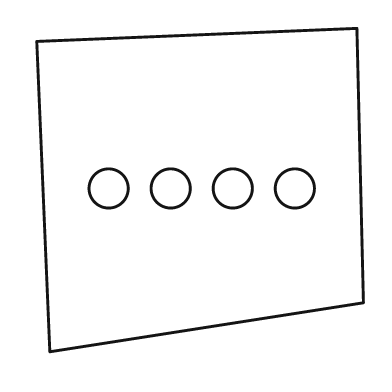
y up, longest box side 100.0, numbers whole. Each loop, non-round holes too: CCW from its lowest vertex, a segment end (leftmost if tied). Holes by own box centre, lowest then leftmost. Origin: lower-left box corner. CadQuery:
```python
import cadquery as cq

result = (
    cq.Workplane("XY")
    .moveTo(4.0, 0.0)
    .lineTo(100.0, 15.0)
    .lineTo(98.0, 99.0)
    .lineTo(0.0, 95.0)
    .close()
    .moveTo(22.0, 50.0)
    .circle(6.0)
    .moveTo(41.0, 50.0)
    .circle(6.0)
    .moveTo(60.0, 50.0)
    .circle(6.0)
    .moveTo(79.0, 50.0)
    .circle(6.0)
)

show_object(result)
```